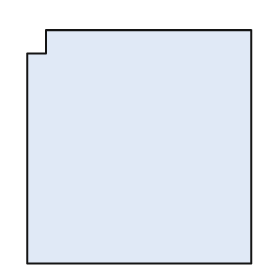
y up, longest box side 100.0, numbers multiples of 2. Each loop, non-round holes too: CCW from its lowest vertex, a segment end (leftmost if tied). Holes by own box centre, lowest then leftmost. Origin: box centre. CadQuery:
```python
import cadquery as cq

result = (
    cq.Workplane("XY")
    .moveTo(-48.0, -50.0)
    .lineTo(48.0, -50.0)
    .lineTo(48.0, 50.0)
    .lineTo(-40.0, 50.0)
    .lineTo(-40.0, 40.0)
    .lineTo(-48.0, 40.0)
    .close()
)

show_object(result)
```